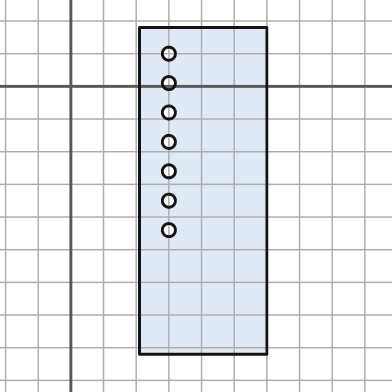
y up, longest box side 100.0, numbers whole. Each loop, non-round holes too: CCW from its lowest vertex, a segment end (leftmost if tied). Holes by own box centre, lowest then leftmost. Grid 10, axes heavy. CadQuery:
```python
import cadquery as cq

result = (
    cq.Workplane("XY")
    .moveTo(21.0, -82.0)
    .lineTo(60.0, -82.0)
    .lineTo(60.0, 18.0)
    .lineTo(21.0, 18.0)
    .close()
    .moveTo(30.0, -44.0)
    .circle(2.0)
    .moveTo(30.0, -35.0)
    .circle(2.0)
    .moveTo(30.0, -26.0)
    .circle(2.0)
    .moveTo(30.0, -17.0)
    .circle(2.0)
    .moveTo(30.0, -8.0)
    .circle(2.0)
    .moveTo(30.0, 1.0)
    .circle(2.0)
    .moveTo(30.0, 10.0)
    .circle(2.0)
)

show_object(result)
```